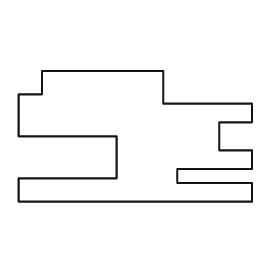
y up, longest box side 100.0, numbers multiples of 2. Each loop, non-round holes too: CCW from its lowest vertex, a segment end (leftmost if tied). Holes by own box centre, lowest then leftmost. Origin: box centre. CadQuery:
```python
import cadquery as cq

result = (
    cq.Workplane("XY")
    .moveTo(-50.0, -28.0)
    .lineTo(50.0, -28.0)
    .lineTo(50.0, -20.0)
    .lineTo(18.0, -20.0)
    .lineTo(18.0, -14.0)
    .lineTo(50.0, -14.0)
    .lineTo(50.0, -6.0)
    .lineTo(36.0, -6.0)
    .lineTo(36.0, 6.0)
    .lineTo(50.0, 6.0)
    .lineTo(50.0, 14.0)
    .lineTo(12.0, 14.0)
    .lineTo(12.0, 28.0)
    .lineTo(-40.0, 28.0)
    .lineTo(-40.0, 18.0)
    .lineTo(-50.0, 18.0)
    .lineTo(-50.0, 0.0)
    .lineTo(-8.0, 0.0)
    .lineTo(-8.0, -18.0)
    .lineTo(-50.0, -18.0)
    .close()
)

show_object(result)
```